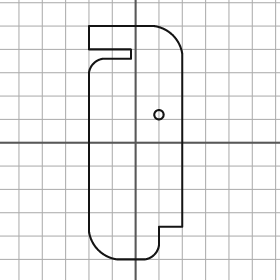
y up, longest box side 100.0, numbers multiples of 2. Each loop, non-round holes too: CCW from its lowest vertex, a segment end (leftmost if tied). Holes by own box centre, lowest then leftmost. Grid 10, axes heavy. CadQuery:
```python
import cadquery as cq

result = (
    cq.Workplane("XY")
    .moveTo(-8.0, -50.0)
    .lineTo(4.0, -50.0)
    .threePointArc((8.0, -48.0), (10.0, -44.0))
    .lineTo(10.0, -36.0)
    .lineTo(20.0, -36.0)
    .lineTo(20.0, 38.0)
    .threePointArc((16.0, 46.0), (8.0, 50.0))
    .lineTo(-20.0, 50.0)
    .lineTo(-20.0, 40.0)
    .lineTo(-2.0, 40.0)
    .lineTo(-2.0, 36.0)
    .lineTo(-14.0, 36.0)
    .threePointArc((-18.0, 34.0), (-20.0, 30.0))
    .lineTo(-20.0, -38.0)
    .threePointArc((-16.0, -46.0), (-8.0, -50.0))
    .close()
    .moveTo(10.0, 12.0)
    .circle(2.0)
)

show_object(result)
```